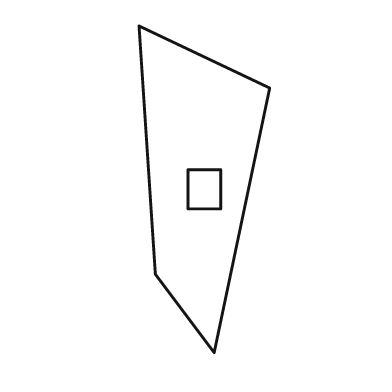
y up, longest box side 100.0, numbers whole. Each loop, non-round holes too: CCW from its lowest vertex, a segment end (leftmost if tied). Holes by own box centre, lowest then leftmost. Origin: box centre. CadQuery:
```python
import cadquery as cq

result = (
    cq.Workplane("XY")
    .moveTo(3.0, -50.0)
    .lineTo(20.0, 31.0)
    .lineTo(-20.0, 50.0)
    .lineTo(-15.0, -26.0)
    .close()
    .moveTo(-5.0, -6.0)
    .lineTo(5.0, -6.0)
    .lineTo(5.0, 6.0)
    .lineTo(-5.0, 6.0)
    .close()
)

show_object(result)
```